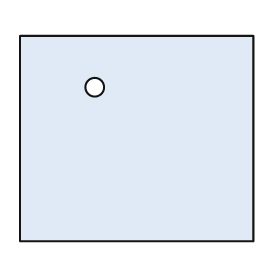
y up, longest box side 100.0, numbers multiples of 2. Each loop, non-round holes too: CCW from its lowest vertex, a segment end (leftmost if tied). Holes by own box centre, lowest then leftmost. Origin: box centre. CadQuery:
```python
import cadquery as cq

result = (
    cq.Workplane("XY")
    .moveTo(-50.0, -44.0)
    .lineTo(50.0, -44.0)
    .lineTo(50.0, 44.0)
    .lineTo(-50.0, 44.0)
    .close()
    .moveTo(-18.0, 22.0)
    .circle(4.0)
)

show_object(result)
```